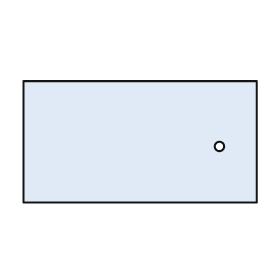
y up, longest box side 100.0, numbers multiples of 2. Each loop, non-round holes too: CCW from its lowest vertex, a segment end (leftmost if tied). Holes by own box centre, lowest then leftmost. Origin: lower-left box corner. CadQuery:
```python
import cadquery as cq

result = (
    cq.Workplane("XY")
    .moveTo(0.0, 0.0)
    .lineTo(100.0, 0.0)
    .lineTo(100.0, 52.0)
    .lineTo(0.0, 52.0)
    .close()
    .moveTo(84.0, 24.0)
    .circle(2.0)
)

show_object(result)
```